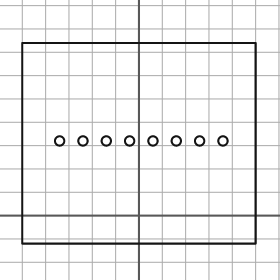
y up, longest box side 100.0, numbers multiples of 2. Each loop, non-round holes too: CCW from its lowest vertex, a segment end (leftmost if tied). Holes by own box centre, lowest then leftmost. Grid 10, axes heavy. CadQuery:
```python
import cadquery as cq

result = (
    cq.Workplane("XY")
    .moveTo(-50.0, -12.0)
    .lineTo(50.0, -12.0)
    .lineTo(50.0, 74.0)
    .lineTo(-50.0, 74.0)
    .close()
    .moveTo(-34.0, 32.0)
    .circle(2.0)
    .moveTo(-24.0, 32.0)
    .circle(2.0)
    .moveTo(-14.0, 32.0)
    .circle(2.0)
    .moveTo(-4.0, 32.0)
    .circle(2.0)
    .moveTo(6.0, 32.0)
    .circle(2.0)
    .moveTo(16.0, 32.0)
    .circle(2.0)
    .moveTo(26.0, 32.0)
    .circle(2.0)
    .moveTo(36.0, 32.0)
    .circle(2.0)
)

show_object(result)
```